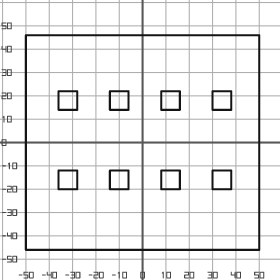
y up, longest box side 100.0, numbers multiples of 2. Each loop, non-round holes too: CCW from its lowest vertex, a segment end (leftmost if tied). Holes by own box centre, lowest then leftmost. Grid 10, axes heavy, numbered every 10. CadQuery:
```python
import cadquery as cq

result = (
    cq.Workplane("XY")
    .moveTo(-50.0, -46.0)
    .lineTo(50.0, -46.0)
    .lineTo(50.0, 46.0)
    .lineTo(-50.0, 46.0)
    .close()
    .moveTo(-36.0, -20.0)
    .lineTo(-28.0, -20.0)
    .lineTo(-28.0, -12.0)
    .lineTo(-36.0, -12.0)
    .close()
    .moveTo(-14.0, -20.0)
    .lineTo(-6.0, -20.0)
    .lineTo(-6.0, -12.0)
    .lineTo(-14.0, -12.0)
    .close()
    .moveTo(8.0, -20.0)
    .lineTo(16.0, -20.0)
    .lineTo(16.0, -12.0)
    .lineTo(8.0, -12.0)
    .close()
    .moveTo(30.0, -20.0)
    .lineTo(38.0, -20.0)
    .lineTo(38.0, -12.0)
    .lineTo(30.0, -12.0)
    .close()
    .moveTo(-36.0, 14.0)
    .lineTo(-28.0, 14.0)
    .lineTo(-28.0, 22.0)
    .lineTo(-36.0, 22.0)
    .close()
    .moveTo(-14.0, 14.0)
    .lineTo(-6.0, 14.0)
    .lineTo(-6.0, 22.0)
    .lineTo(-14.0, 22.0)
    .close()
    .moveTo(8.0, 14.0)
    .lineTo(16.0, 14.0)
    .lineTo(16.0, 22.0)
    .lineTo(8.0, 22.0)
    .close()
    .moveTo(30.0, 14.0)
    .lineTo(38.0, 14.0)
    .lineTo(38.0, 22.0)
    .lineTo(30.0, 22.0)
    .close()
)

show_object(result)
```